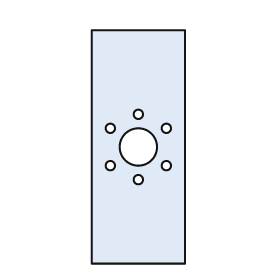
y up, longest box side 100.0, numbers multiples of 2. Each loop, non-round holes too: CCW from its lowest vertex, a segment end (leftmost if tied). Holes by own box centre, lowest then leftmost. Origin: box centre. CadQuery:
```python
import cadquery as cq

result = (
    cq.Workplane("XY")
    .moveTo(-20.0, -50.0)
    .lineTo(20.0, -50.0)
    .lineTo(20.0, 50.0)
    .lineTo(-20.0, 50.0)
    .close()
    .moveTo(0.0, -14.0)
    .circle(2.0)
    .moveTo(-12.0, -8.0)
    .circle(2.0)
    .moveTo(12.0, -8.0)
    .circle(2.0)
    .moveTo(0.0, 0.0)
    .circle(8.0)
    .moveTo(-12.0, 8.0)
    .circle(2.0)
    .moveTo(12.0, 8.0)
    .circle(2.0)
    .moveTo(0.0, 14.0)
    .circle(2.0)
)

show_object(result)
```